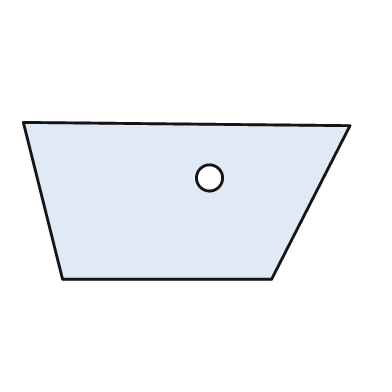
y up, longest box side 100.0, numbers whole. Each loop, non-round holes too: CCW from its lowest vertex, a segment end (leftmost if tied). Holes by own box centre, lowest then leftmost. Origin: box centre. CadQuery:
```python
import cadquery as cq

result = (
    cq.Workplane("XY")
    .moveTo(-38.0, -24.0)
    .lineTo(26.0, -24.0)
    .lineTo(50.0, 23.0)
    .lineTo(-50.0, 24.0)
    .close()
    .moveTo(7.0, 7.0)
    .circle(4.0)
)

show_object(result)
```